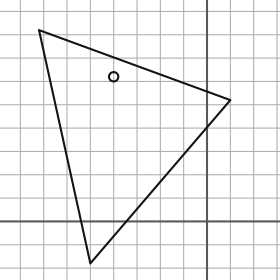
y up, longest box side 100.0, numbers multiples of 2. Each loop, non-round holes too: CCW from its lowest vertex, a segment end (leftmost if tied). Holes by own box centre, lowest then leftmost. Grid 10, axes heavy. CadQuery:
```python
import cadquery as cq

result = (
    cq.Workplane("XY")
    .moveTo(-50.0, -18.0)
    .lineTo(10.0, 52.0)
    .lineTo(-72.0, 82.0)
    .close()
    .moveTo(-40.0, 62.0)
    .circle(2.0)
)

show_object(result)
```